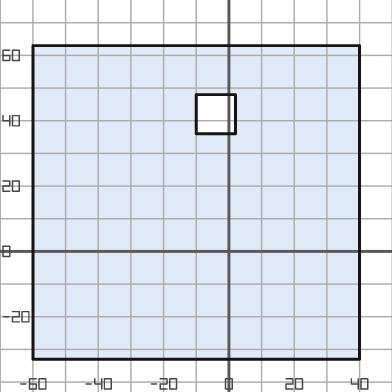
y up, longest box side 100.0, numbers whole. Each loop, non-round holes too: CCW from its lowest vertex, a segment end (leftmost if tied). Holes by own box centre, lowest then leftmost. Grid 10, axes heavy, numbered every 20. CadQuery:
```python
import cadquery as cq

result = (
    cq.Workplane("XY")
    .moveTo(-60.0, -33.0)
    .lineTo(40.0, -33.0)
    .lineTo(40.0, 63.0)
    .lineTo(-60.0, 63.0)
    .close()
    .moveTo(-10.0, 36.0)
    .lineTo(2.0, 36.0)
    .lineTo(2.0, 48.0)
    .lineTo(-10.0, 48.0)
    .close()
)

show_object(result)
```